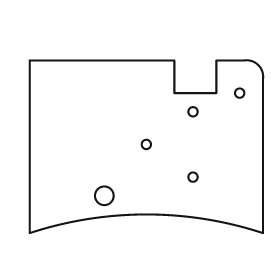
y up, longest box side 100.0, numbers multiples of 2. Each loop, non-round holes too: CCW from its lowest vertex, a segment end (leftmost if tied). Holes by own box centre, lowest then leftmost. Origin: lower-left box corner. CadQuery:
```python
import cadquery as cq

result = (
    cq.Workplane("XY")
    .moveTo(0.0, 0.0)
    .threePointArc((50.0, 8.0), (100.0, 0.0))
    .lineTo(100.0, 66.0)
    .threePointArc((98.0, 72.0), (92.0, 74.0))
    .lineTo(80.0, 74.0)
    .lineTo(80.0, 60.0)
    .lineTo(62.0, 60.0)
    .lineTo(62.0, 74.0)
    .lineTo(0.0, 74.0)
    .close()
    .moveTo(32.0, 16.0)
    .circle(4.0)
    .moveTo(70.0, 24.0)
    .circle(2.0)
    .moveTo(50.0, 38.0)
    .circle(2.0)
    .moveTo(70.0, 52.0)
    .circle(2.0)
    .moveTo(90.0, 60.0)
    .circle(2.0)
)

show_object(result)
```